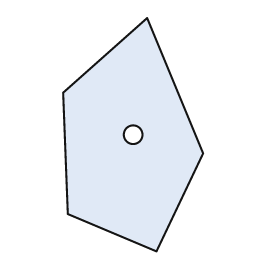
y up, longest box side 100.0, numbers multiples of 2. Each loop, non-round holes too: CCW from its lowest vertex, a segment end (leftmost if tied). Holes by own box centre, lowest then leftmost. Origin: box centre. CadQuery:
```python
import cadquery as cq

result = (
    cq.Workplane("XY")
    .moveTo(10.0, -50.0)
    .lineTo(30.0, -8.0)
    .lineTo(6.0, 50.0)
    .lineTo(-30.0, 18.0)
    .lineTo(-28.0, -34.0)
    .close()
    .moveTo(0.0, 0.0)
    .circle(4.0)
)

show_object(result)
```